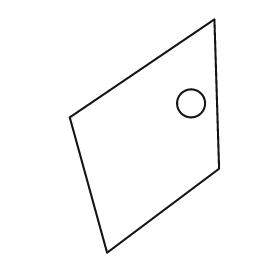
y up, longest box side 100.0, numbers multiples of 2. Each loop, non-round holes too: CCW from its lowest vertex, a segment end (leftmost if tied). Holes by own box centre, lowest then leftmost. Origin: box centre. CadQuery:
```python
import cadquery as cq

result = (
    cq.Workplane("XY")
    .moveTo(-16.0, -50.0)
    .lineTo(32.0, -14.0)
    .lineTo(30.0, 50.0)
    .lineTo(-32.0, 8.0)
    .close()
    .moveTo(20.0, 14.0)
    .circle(6.0)
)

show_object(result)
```